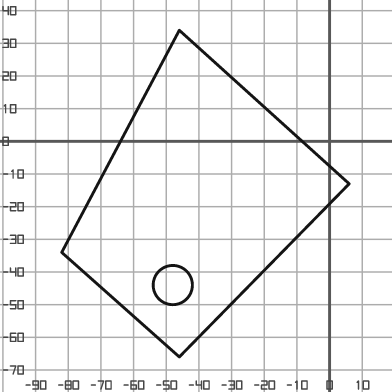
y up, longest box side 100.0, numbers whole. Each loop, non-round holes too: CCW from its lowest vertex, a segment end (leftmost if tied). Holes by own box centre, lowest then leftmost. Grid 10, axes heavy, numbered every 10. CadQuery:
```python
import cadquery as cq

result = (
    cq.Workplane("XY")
    .moveTo(-46.0, -66.0)
    .lineTo(6.0, -13.0)
    .lineTo(-46.0, 34.0)
    .lineTo(-82.0, -34.0)
    .close()
    .moveTo(-48.0, -44.0)
    .circle(6.0)
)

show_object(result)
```